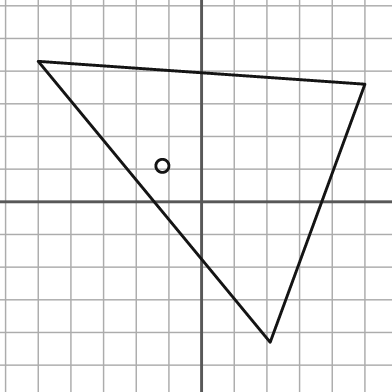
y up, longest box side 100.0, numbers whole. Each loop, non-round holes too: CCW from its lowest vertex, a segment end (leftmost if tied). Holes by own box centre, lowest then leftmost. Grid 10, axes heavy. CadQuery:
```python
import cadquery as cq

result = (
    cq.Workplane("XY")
    .moveTo(21.0, -43.0)
    .lineTo(50.0, 36.0)
    .lineTo(-50.0, 43.0)
    .close()
    .moveTo(-12.0, 11.0)
    .circle(2.0)
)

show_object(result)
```